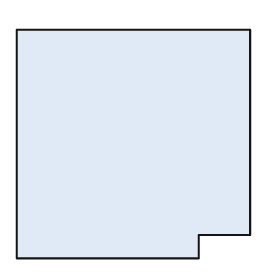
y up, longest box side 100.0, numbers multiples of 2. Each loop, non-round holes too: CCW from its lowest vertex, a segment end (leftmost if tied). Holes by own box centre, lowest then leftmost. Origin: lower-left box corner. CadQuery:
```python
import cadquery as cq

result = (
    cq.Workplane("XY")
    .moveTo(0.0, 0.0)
    .lineTo(78.0, 0.0)
    .lineTo(78.0, 10.0)
    .lineTo(100.0, 10.0)
    .lineTo(100.0, 98.0)
    .lineTo(0.0, 98.0)
    .close()
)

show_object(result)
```